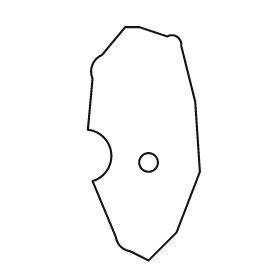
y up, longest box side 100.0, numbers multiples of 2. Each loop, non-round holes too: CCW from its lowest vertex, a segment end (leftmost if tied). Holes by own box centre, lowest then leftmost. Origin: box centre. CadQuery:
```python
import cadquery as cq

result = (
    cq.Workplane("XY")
    .moveTo(2.0, -50.0)
    .lineTo(14.0, -38.0)
    .lineTo(24.0, -12.0)
    .lineTo(22.0, 18.0)
    .lineTo(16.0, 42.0)
    .threePointArc((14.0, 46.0), (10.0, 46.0))
    .lineTo(-2.0, 50.0)
    .lineTo(-8.0, 50.0)
    .lineTo(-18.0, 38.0)
    .threePointArc((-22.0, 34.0), (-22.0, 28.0))
    .lineTo(-24.0, 6.0)
    .threePointArc((-14.0, -4.0), (-22.0, -16.0))
    .lineTo(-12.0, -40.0)
    .threePointArc((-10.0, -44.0), (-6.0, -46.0))
    .close()
    .moveTo(2.0, -8.0)
    .circle(4.0)
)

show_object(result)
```